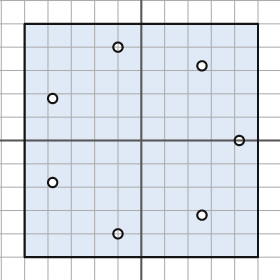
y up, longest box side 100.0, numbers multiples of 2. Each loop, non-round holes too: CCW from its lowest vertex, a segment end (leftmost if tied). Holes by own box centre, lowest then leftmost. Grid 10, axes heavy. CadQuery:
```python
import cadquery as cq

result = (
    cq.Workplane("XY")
    .moveTo(-50.0, -50.0)
    .lineTo(50.0, -50.0)
    .lineTo(50.0, 50.0)
    .lineTo(-50.0, 50.0)
    .close()
    .moveTo(-10.0, -40.0)
    .circle(2.0)
    .moveTo(26.0, -32.0)
    .circle(2.0)
    .moveTo(-38.0, -18.0)
    .circle(2.0)
    .moveTo(42.0, 0.0)
    .circle(2.0)
    .moveTo(-38.0, 18.0)
    .circle(2.0)
    .moveTo(26.0, 32.0)
    .circle(2.0)
    .moveTo(-10.0, 40.0)
    .circle(2.0)
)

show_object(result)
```